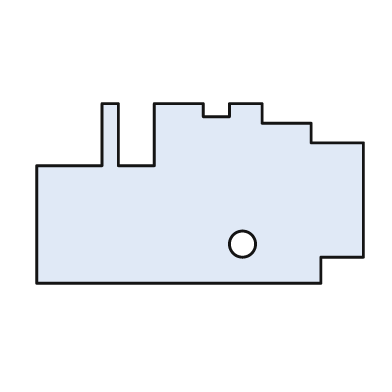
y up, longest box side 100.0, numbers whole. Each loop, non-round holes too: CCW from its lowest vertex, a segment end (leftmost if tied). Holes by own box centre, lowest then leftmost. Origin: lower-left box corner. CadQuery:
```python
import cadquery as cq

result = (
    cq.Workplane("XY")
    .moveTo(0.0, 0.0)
    .lineTo(87.0, 0.0)
    .lineTo(87.0, 8.0)
    .lineTo(100.0, 8.0)
    .lineTo(100.0, 43.0)
    .lineTo(84.0, 43.0)
    .lineTo(84.0, 49.0)
    .lineTo(69.0, 49.0)
    .lineTo(69.0, 55.0)
    .lineTo(59.0, 55.0)
    .lineTo(59.0, 51.0)
    .lineTo(51.0, 51.0)
    .lineTo(51.0, 55.0)
    .lineTo(36.0, 55.0)
    .lineTo(36.0, 36.0)
    .lineTo(25.0, 36.0)
    .lineTo(25.0, 55.0)
    .lineTo(20.0, 55.0)
    .lineTo(20.0, 36.0)
    .lineTo(0.0, 36.0)
    .close()
    .moveTo(63.0, 12.0)
    .circle(4.0)
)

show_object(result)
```